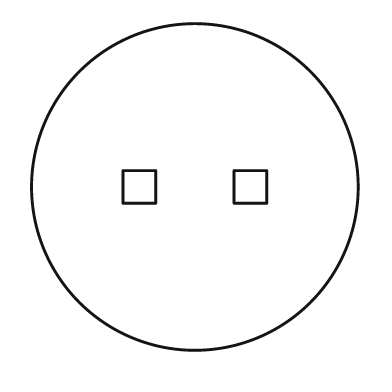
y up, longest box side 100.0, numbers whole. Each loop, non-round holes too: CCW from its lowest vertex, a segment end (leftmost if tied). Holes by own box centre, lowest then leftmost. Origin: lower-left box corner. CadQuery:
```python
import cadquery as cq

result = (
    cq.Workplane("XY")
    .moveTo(50.0, 50.0)
    .circle(50.0)
    .moveTo(28.0, 45.0)
    .lineTo(38.0, 45.0)
    .lineTo(38.0, 55.0)
    .lineTo(28.0, 55.0)
    .close()
    .moveTo(62.0, 45.0)
    .lineTo(72.0, 45.0)
    .lineTo(72.0, 55.0)
    .lineTo(62.0, 55.0)
    .close()
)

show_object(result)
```